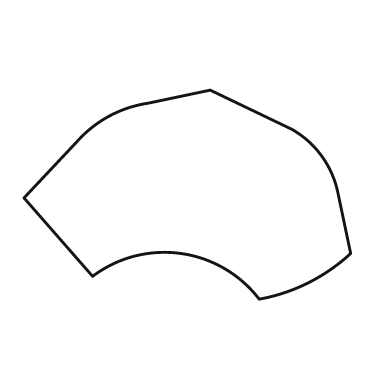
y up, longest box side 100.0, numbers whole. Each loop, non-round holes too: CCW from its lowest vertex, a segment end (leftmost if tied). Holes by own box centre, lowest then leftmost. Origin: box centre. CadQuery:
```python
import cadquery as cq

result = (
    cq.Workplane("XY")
    .moveTo(22.0, -32.0)
    .threePointArc((37.0, -27.0), (50.0, -18.0))
    .lineTo(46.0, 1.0)
    .threePointArc((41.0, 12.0), (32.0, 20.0))
    .lineTo(7.0, 32.0)
    .lineTo(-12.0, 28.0)
    .threePointArc((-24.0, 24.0), (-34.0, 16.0))
    .lineTo(-50.0, -1.0)
    .lineTo(-29.0, -25.0)
    .threePointArc((-2.0, -18.0), (22.0, -32.0))
    .close()
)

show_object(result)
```